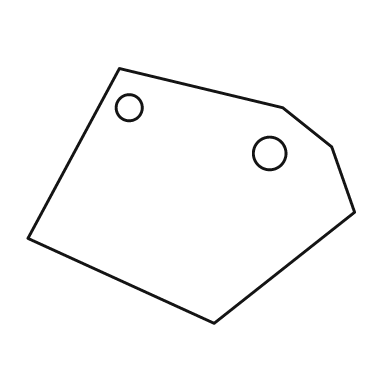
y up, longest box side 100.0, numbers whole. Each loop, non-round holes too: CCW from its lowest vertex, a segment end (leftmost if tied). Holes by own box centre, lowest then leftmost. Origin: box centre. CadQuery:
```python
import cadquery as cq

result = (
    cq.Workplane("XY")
    .moveTo(7.0, -39.0)
    .lineTo(50.0, -5.0)
    .lineTo(43.0, 15.0)
    .lineTo(28.0, 27.0)
    .lineTo(-22.0, 39.0)
    .lineTo(-50.0, -13.0)
    .close()
    .moveTo(24.0, 13.0)
    .circle(5.0)
    .moveTo(-19.0, 27.0)
    .circle(4.0)
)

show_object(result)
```